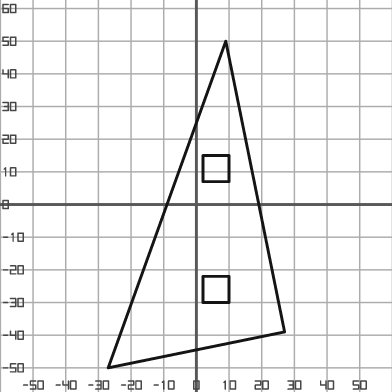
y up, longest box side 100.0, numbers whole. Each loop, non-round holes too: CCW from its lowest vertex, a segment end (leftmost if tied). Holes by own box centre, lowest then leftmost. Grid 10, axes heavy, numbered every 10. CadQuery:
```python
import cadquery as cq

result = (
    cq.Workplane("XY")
    .moveTo(-27.0, -50.0)
    .lineTo(27.0, -39.0)
    .lineTo(9.0, 50.0)
    .close()
    .moveTo(2.0, -30.0)
    .lineTo(10.0, -30.0)
    .lineTo(10.0, -22.0)
    .lineTo(2.0, -22.0)
    .close()
    .moveTo(2.0, 7.0)
    .lineTo(10.0, 7.0)
    .lineTo(10.0, 15.0)
    .lineTo(2.0, 15.0)
    .close()
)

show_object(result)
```